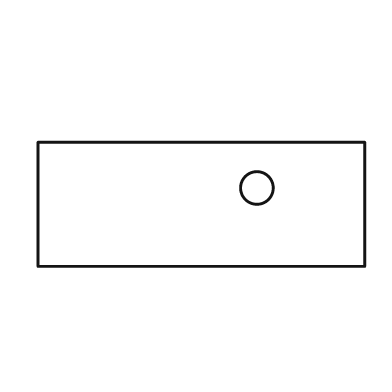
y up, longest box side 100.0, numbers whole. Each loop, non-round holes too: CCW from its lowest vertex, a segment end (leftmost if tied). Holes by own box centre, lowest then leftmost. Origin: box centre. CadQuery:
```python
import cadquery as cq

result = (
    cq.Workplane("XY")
    .moveTo(-50.0, -19.0)
    .lineTo(50.0, -19.0)
    .lineTo(50.0, 19.0)
    .lineTo(-50.0, 19.0)
    .close()
    .moveTo(17.0, 5.0)
    .circle(5.0)
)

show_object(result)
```